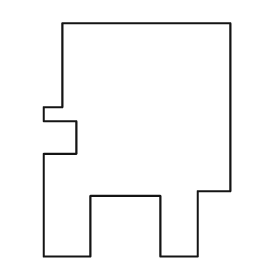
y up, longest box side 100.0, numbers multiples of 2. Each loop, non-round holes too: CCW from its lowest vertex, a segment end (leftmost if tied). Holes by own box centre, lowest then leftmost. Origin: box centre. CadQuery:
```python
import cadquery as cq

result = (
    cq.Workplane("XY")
    .moveTo(-40.0, -50.0)
    .lineTo(-20.0, -50.0)
    .lineTo(-20.0, -24.0)
    .lineTo(10.0, -24.0)
    .lineTo(10.0, -50.0)
    .lineTo(26.0, -50.0)
    .lineTo(26.0, -22.0)
    .lineTo(40.0, -22.0)
    .lineTo(40.0, 50.0)
    .lineTo(-32.0, 50.0)
    .lineTo(-32.0, 14.0)
    .lineTo(-40.0, 14.0)
    .lineTo(-40.0, 8.0)
    .lineTo(-26.0, 8.0)
    .lineTo(-26.0, -6.0)
    .lineTo(-40.0, -6.0)
    .close()
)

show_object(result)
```